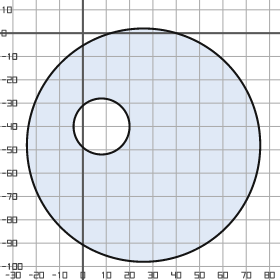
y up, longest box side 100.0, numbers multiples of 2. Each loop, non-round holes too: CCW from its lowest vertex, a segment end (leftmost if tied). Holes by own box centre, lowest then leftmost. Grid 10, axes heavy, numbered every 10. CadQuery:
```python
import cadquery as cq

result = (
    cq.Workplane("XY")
    .moveTo(26.0, -48.0)
    .circle(50.0)
    .moveTo(8.0, -40.0)
    .circle(12.0)
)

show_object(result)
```